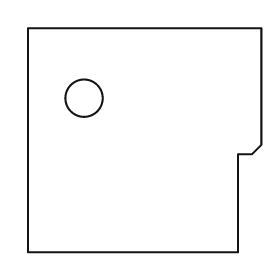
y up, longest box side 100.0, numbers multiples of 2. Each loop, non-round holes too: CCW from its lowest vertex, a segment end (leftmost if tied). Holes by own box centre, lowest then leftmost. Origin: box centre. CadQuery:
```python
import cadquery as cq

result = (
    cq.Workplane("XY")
    .moveTo(-50.0, -48.0)
    .lineTo(40.0, -48.0)
    .lineTo(40.0, -6.0)
    .lineTo(46.0, -6.0)
    .lineTo(50.0, -2.0)
    .lineTo(50.0, 48.0)
    .lineTo(-50.0, 48.0)
    .close()
    .moveTo(-26.0, 18.0)
    .circle(8.0)
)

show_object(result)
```